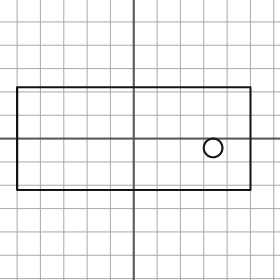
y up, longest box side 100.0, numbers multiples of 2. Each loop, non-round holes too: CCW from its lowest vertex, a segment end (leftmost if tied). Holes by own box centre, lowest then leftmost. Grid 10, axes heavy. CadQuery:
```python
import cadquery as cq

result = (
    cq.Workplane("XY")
    .moveTo(-50.0, -22.0)
    .lineTo(50.0, -22.0)
    .lineTo(50.0, 22.0)
    .lineTo(-50.0, 22.0)
    .close()
    .moveTo(34.0, -4.0)
    .circle(4.0)
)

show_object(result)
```